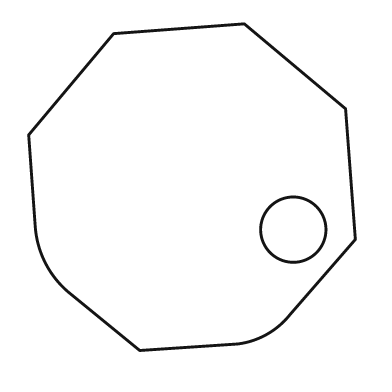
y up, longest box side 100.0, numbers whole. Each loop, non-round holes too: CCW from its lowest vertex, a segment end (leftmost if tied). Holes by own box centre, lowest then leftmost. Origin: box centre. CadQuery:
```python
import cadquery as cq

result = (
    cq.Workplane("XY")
    .moveTo(-16.0, -50.0)
    .lineTo(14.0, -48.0)
    .threePointArc((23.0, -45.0), (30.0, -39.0))
    .lineTo(50.0, -16.0)
    .lineTo(47.0, 24.0)
    .lineTo(16.0, 50.0)
    .lineTo(-24.0, 47.0)
    .lineTo(-50.0, 16.0)
    .lineTo(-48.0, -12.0)
    .threePointArc((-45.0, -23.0), (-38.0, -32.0))
    .close()
    .moveTo(31.0, -13.0)
    .circle(10.0)
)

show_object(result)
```